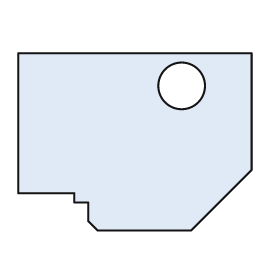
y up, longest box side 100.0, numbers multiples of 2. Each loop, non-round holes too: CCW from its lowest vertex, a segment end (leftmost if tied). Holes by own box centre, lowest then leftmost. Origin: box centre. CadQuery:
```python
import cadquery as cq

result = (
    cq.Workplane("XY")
    .moveTo(-16.0, -38.0)
    .lineTo(24.0, -38.0)
    .lineTo(50.0, -12.0)
    .lineTo(50.0, 38.0)
    .lineTo(-50.0, 38.0)
    .lineTo(-50.0, -22.0)
    .lineTo(-26.0, -22.0)
    .lineTo(-26.0, -26.0)
    .lineTo(-20.0, -26.0)
    .lineTo(-20.0, -34.0)
    .close()
    .moveTo(20.0, 24.0)
    .circle(10.0)
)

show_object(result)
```